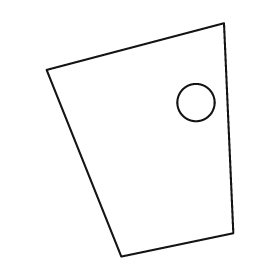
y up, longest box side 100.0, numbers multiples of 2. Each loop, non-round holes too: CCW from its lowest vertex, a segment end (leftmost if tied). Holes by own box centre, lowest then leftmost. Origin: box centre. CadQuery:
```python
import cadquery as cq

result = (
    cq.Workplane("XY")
    .moveTo(-8.0, -50.0)
    .lineTo(40.0, -40.0)
    .lineTo(36.0, 50.0)
    .lineTo(-40.0, 30.0)
    .close()
    .moveTo(24.0, 16.0)
    .circle(8.0)
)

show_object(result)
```